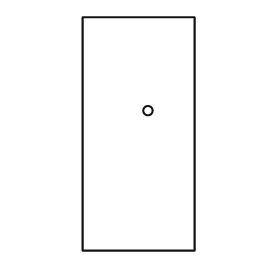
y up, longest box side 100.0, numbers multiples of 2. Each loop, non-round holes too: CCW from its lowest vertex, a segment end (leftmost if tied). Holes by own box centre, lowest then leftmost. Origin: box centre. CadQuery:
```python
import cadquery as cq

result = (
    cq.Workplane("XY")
    .moveTo(-24.0, -50.0)
    .lineTo(24.0, -50.0)
    .lineTo(24.0, 50.0)
    .lineTo(-24.0, 50.0)
    .close()
    .moveTo(4.0, 10.0)
    .circle(2.0)
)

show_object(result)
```